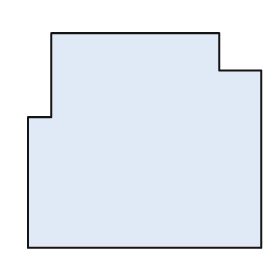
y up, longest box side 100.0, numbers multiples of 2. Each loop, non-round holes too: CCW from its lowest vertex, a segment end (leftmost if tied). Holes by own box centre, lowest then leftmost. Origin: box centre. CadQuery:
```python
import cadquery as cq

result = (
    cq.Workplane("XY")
    .moveTo(-50.0, -46.0)
    .lineTo(50.0, -46.0)
    .lineTo(50.0, 30.0)
    .lineTo(32.0, 30.0)
    .lineTo(32.0, 46.0)
    .lineTo(-40.0, 46.0)
    .lineTo(-40.0, 10.0)
    .lineTo(-50.0, 10.0)
    .close()
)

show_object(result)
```